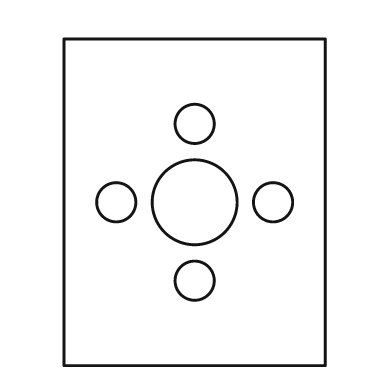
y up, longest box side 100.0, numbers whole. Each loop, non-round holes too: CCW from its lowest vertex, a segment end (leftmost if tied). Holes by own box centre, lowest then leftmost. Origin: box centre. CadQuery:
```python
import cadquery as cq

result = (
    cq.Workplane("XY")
    .moveTo(-40.0, -50.0)
    .lineTo(40.0, -50.0)
    .lineTo(40.0, 50.0)
    .lineTo(-40.0, 50.0)
    .close()
    .moveTo(0.0, -24.0)
    .circle(6.0)
    .moveTo(-24.0, 0.0)
    .circle(6.0)
    .moveTo(0.0, 0.0)
    .circle(13.0)
    .moveTo(24.0, 0.0)
    .circle(6.0)
    .moveTo(0.0, 24.0)
    .circle(6.0)
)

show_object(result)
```